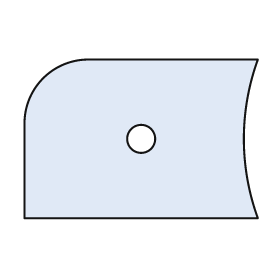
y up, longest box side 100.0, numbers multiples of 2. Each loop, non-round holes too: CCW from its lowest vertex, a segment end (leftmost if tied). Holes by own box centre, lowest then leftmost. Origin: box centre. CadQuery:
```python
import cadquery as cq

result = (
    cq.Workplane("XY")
    .moveTo(-50.0, -34.0)
    .lineTo(50.0, -34.0)
    .threePointArc((44.0, 0.0), (50.0, 34.0))
    .lineTo(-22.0, 34.0)
    .threePointArc((-42.0, 26.0), (-50.0, 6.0))
    .close()
    .moveTo(0.0, 0.0)
    .circle(6.0)
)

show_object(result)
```